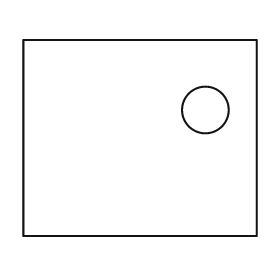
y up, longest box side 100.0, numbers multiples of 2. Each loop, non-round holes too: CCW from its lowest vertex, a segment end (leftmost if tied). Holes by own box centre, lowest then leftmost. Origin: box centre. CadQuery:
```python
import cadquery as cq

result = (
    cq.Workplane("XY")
    .moveTo(-50.0, -42.0)
    .lineTo(50.0, -42.0)
    .lineTo(50.0, 42.0)
    .lineTo(-50.0, 42.0)
    .close()
    .moveTo(28.0, 12.0)
    .circle(10.0)
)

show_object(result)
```